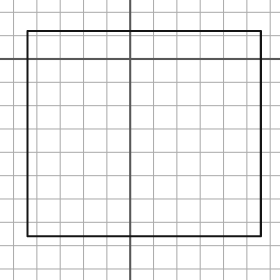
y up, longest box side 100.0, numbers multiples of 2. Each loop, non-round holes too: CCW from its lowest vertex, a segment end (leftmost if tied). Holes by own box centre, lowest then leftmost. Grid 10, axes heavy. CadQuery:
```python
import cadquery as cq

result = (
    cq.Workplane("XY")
    .moveTo(-44.0, -76.0)
    .lineTo(56.0, -76.0)
    .lineTo(56.0, 12.0)
    .lineTo(-44.0, 12.0)
    .close()
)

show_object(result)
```